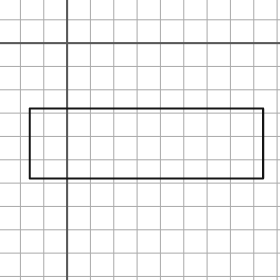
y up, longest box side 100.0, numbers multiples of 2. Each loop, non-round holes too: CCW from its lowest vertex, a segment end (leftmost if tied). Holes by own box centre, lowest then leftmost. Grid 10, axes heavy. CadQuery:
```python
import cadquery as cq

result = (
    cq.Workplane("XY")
    .moveTo(-16.0, -58.0)
    .lineTo(84.0, -58.0)
    .lineTo(84.0, -28.0)
    .lineTo(-16.0, -28.0)
    .close()
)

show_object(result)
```